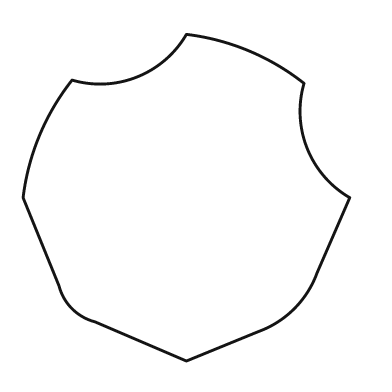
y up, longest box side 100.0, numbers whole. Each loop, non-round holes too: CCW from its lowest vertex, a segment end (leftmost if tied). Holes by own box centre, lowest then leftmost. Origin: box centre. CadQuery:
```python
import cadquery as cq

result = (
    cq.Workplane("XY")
    .moveTo(0.0, -50.0)
    .lineTo(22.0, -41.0)
    .threePointArc((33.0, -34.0), (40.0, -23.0))
    .lineTo(50.0, 0.0)
    .threePointArc((37.0, 15.0), (36.0, 35.0))
    .threePointArc((19.0, 45.0), (0.0, 50.0))
    .threePointArc((-15.0, 37.0), (-35.0, 36.0))
    .threePointArc((-45.0, 19.0), (-50.0, 0.0))
    .lineTo(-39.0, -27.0)
    .threePointArc((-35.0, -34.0), (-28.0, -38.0))
    .close()
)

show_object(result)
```